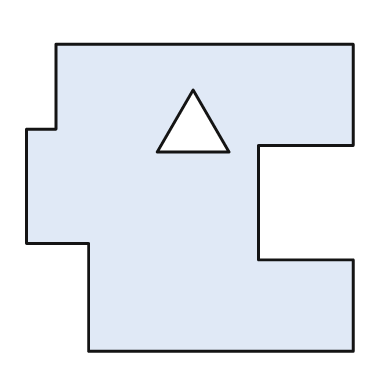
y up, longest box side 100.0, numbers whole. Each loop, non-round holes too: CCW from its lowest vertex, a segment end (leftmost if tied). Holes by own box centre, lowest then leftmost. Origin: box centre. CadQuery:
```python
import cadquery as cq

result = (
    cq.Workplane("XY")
    .moveTo(-31.0, -47.0)
    .lineTo(50.0, -47.0)
    .lineTo(50.0, -19.0)
    .lineTo(21.0, -19.0)
    .lineTo(21.0, 16.0)
    .lineTo(50.0, 16.0)
    .lineTo(50.0, 47.0)
    .lineTo(-41.0, 47.0)
    .lineTo(-41.0, 21.0)
    .lineTo(-50.0, 21.0)
    .lineTo(-50.0, -14.0)
    .lineTo(-31.0, -14.0)
    .close()
    .moveTo(-10.0, 14.0)
    .lineTo(12.0, 14.0)
    .lineTo(1.0, 33.0)
    .close()
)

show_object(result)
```